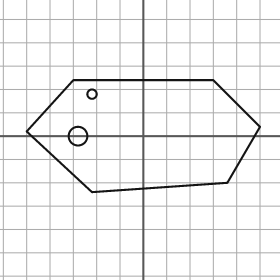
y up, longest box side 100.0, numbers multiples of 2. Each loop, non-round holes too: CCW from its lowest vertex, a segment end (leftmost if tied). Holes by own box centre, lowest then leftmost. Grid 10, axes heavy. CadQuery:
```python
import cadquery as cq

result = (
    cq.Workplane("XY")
    .moveTo(-22.0, -24.0)
    .lineTo(36.0, -20.0)
    .lineTo(50.0, 4.0)
    .lineTo(30.0, 24.0)
    .lineTo(-30.0, 24.0)
    .lineTo(-50.0, 2.0)
    .close()
    .moveTo(-28.0, 0.0)
    .circle(4.0)
    .moveTo(-22.0, 18.0)
    .circle(2.0)
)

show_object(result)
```